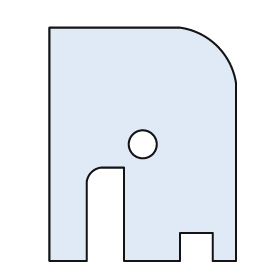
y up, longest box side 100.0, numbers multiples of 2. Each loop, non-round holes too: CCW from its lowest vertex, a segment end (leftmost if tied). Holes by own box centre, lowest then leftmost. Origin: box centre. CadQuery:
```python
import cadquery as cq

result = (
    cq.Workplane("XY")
    .moveTo(-40.0, -50.0)
    .lineTo(-24.0, -50.0)
    .lineTo(-24.0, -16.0)
    .threePointArc((-22.0, -12.0), (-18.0, -10.0))
    .lineTo(-8.0, -10.0)
    .lineTo(-8.0, -50.0)
    .lineTo(16.0, -50.0)
    .lineTo(16.0, -38.0)
    .lineTo(30.0, -38.0)
    .lineTo(30.0, -50.0)
    .lineTo(40.0, -50.0)
    .lineTo(40.0, 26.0)
    .threePointArc((32.0, 42.0), (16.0, 50.0))
    .lineTo(-40.0, 50.0)
    .close()
    .moveTo(0.0, 0.0)
    .circle(6.0)
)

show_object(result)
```